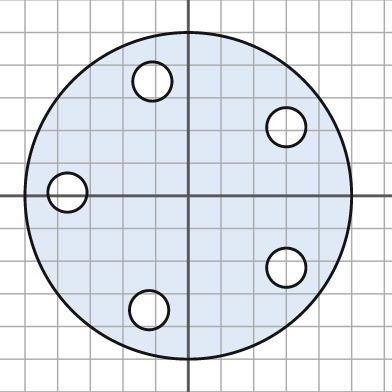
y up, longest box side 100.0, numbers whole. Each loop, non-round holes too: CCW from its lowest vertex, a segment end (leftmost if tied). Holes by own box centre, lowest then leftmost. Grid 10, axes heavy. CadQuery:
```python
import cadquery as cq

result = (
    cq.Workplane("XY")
    .moveTo(0.0, 0.0)
    .circle(50.0)
    .moveTo(-12.0, -35.0)
    .circle(6.0)
    .moveTo(30.0, -22.0)
    .circle(6.0)
    .moveTo(-37.0, 1.0)
    .circle(6.0)
    .moveTo(30.0, 21.0)
    .circle(6.0)
    .moveTo(-11.0, 35.0)
    .circle(6.0)
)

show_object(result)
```